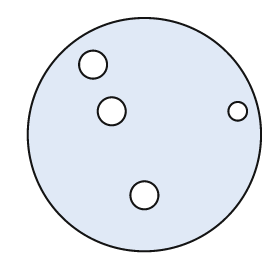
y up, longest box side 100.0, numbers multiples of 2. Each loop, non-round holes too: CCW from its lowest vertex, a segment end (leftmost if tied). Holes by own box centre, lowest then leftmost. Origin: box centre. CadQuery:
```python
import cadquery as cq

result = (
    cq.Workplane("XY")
    .moveTo(0.0, 0.0)
    .circle(50.0)
    .moveTo(0.0, -26.0)
    .circle(6.0)
    .moveTo(-14.0, 10.0)
    .circle(6.0)
    .moveTo(40.0, 10.0)
    .circle(4.0)
    .moveTo(-22.0, 30.0)
    .circle(6.0)
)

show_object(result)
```